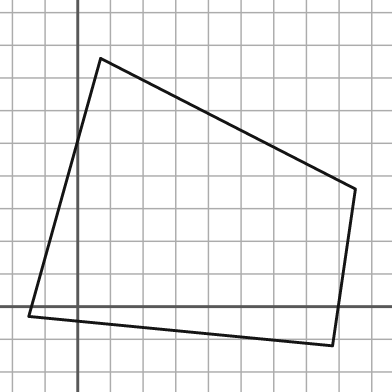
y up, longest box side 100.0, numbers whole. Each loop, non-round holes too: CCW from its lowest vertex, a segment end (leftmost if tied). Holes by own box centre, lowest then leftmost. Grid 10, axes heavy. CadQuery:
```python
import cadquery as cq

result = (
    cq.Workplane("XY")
    .moveTo(78.0, -12.0)
    .lineTo(85.0, 36.0)
    .lineTo(7.0, 76.0)
    .lineTo(-15.0, -3.0)
    .close()
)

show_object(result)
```